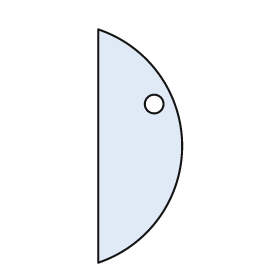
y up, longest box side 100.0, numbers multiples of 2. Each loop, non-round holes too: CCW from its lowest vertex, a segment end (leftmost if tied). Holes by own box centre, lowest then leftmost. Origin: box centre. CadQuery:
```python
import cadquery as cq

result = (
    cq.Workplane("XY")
    .moveTo(-18.0, -50.0)
    .threePointArc((18.0, 0.0), (-18.0, 50.0))
    .close()
    .moveTo(6.0, 18.0)
    .circle(4.0)
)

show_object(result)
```